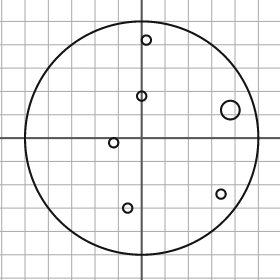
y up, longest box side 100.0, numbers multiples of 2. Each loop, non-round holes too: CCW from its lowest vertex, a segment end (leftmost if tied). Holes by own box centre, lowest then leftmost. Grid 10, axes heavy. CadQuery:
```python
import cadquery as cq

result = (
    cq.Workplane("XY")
    .moveTo(0.0, 0.0)
    .circle(50.0)
    .moveTo(-6.0, -30.0)
    .circle(2.0)
    .moveTo(34.0, -24.0)
    .circle(2.0)
    .moveTo(-12.0, -2.0)
    .circle(2.0)
    .moveTo(38.0, 12.0)
    .circle(4.0)
    .moveTo(0.0, 18.0)
    .circle(2.0)
    .moveTo(2.0, 42.0)
    .circle(2.0)
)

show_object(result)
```